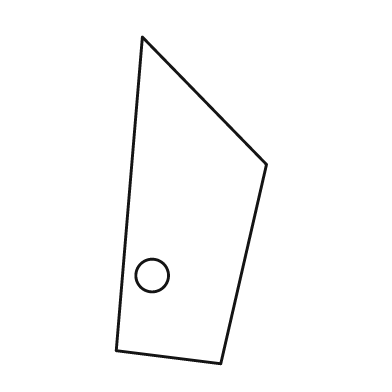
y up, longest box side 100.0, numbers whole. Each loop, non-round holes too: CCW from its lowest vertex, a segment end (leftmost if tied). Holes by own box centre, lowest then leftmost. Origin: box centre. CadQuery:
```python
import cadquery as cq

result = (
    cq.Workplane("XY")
    .moveTo(9.0, -50.0)
    .lineTo(23.0, 11.0)
    .lineTo(-15.0, 50.0)
    .lineTo(-23.0, -46.0)
    .close()
    .moveTo(-12.0, -23.0)
    .circle(5.0)
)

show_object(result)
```